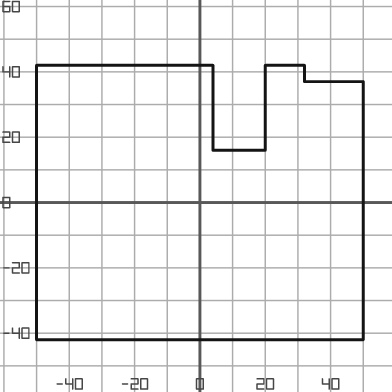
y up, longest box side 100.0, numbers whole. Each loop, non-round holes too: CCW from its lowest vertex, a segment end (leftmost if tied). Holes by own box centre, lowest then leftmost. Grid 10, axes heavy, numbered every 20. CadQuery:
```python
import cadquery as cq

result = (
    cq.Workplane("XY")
    .moveTo(-50.0, -42.0)
    .lineTo(50.0, -42.0)
    .lineTo(50.0, 37.0)
    .lineTo(32.0, 37.0)
    .lineTo(32.0, 42.0)
    .lineTo(20.0, 42.0)
    .lineTo(20.0, 16.0)
    .lineTo(4.0, 16.0)
    .lineTo(4.0, 42.0)
    .lineTo(-50.0, 42.0)
    .close()
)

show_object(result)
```